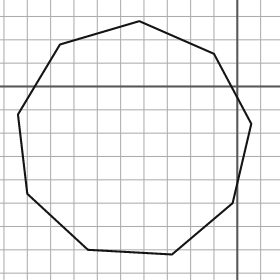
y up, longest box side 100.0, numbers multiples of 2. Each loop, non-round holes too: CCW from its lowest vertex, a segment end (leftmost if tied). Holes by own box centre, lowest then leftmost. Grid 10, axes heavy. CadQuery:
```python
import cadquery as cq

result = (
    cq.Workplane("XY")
    .moveTo(-28.0, -72.0)
    .lineTo(-2.0, -50.0)
    .lineTo(6.0, -16.0)
    .lineTo(-10.0, 14.0)
    .lineTo(-42.0, 28.0)
    .lineTo(-76.0, 18.0)
    .lineTo(-94.0, -12.0)
    .lineTo(-90.0, -46.0)
    .lineTo(-64.0, -70.0)
    .close()
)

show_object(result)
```